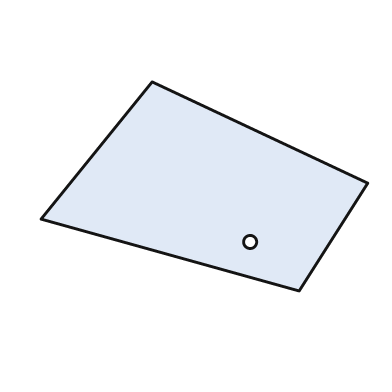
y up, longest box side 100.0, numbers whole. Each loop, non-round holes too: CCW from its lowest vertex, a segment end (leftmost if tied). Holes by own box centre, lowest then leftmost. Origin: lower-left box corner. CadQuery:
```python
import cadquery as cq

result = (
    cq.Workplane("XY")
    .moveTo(79.0, 0.0)
    .lineTo(100.0, 33.0)
    .lineTo(34.0, 64.0)
    .lineTo(0.0, 22.0)
    .close()
    .moveTo(64.0, 15.0)
    .circle(2.0)
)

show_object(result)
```